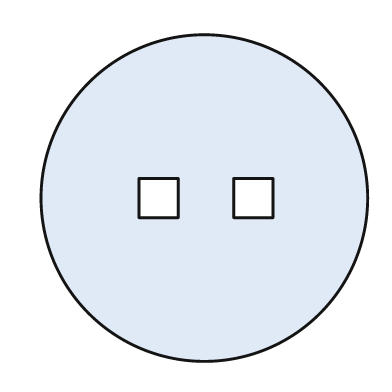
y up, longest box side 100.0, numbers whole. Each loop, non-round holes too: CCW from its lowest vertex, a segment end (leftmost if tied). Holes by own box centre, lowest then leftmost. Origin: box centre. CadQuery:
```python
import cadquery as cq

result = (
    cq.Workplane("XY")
    .moveTo(0.0, 0.0)
    .circle(50.0)
    .moveTo(-20.0, -6.0)
    .lineTo(-8.0, -6.0)
    .lineTo(-8.0, 6.0)
    .lineTo(-20.0, 6.0)
    .close()
    .moveTo(9.0, -6.0)
    .lineTo(21.0, -6.0)
    .lineTo(21.0, 6.0)
    .lineTo(9.0, 6.0)
    .close()
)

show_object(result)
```